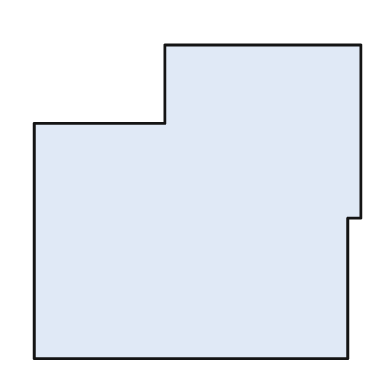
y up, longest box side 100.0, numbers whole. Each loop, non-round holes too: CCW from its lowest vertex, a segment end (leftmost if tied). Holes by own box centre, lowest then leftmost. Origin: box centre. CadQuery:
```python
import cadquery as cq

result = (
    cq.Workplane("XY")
    .moveTo(-50.0, -48.0)
    .lineTo(46.0, -48.0)
    .lineTo(46.0, -5.0)
    .lineTo(50.0, -5.0)
    .lineTo(50.0, 48.0)
    .lineTo(-10.0, 48.0)
    .lineTo(-10.0, 24.0)
    .lineTo(-50.0, 24.0)
    .close()
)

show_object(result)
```